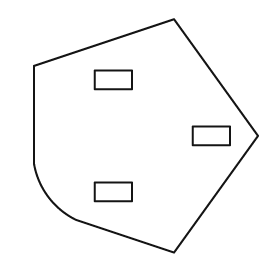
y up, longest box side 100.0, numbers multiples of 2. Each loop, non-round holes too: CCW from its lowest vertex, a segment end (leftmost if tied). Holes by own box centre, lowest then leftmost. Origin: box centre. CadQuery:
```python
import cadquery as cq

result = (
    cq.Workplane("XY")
    .moveTo(12.0, -50.0)
    .lineTo(48.0, 0.0)
    .lineTo(12.0, 50.0)
    .lineTo(-48.0, 30.0)
    .lineTo(-48.0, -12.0)
    .threePointArc((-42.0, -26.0), (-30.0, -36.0))
    .close()
    .moveTo(-22.0, -28.0)
    .lineTo(-6.0, -28.0)
    .lineTo(-6.0, -20.0)
    .lineTo(-22.0, -20.0)
    .close()
    .moveTo(20.0, -4.0)
    .lineTo(36.0, -4.0)
    .lineTo(36.0, 4.0)
    .lineTo(20.0, 4.0)
    .close()
    .moveTo(-22.0, 20.0)
    .lineTo(-6.0, 20.0)
    .lineTo(-6.0, 28.0)
    .lineTo(-22.0, 28.0)
    .close()
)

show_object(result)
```